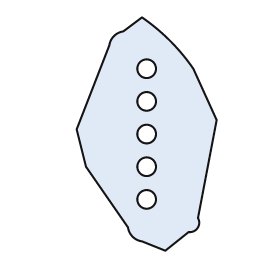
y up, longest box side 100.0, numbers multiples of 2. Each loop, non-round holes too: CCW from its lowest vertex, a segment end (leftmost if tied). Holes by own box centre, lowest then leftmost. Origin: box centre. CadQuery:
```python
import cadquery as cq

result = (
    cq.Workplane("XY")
    .moveTo(8.0, -50.0)
    .lineTo(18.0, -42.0)
    .threePointArc((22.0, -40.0), (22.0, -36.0))
    .lineTo(30.0, 6.0)
    .lineTo(20.0, 28.0)
    .threePointArc((10.0, 40.0), (-2.0, 50.0))
    .lineTo(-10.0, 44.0)
    .threePointArc((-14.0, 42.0), (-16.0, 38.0))
    .lineTo(-30.0, 2.0)
    .lineTo(-26.0, -14.0)
    .lineTo(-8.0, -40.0)
    .threePointArc((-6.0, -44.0), (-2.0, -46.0))
    .close()
    .moveTo(0.0, -28.0)
    .circle(4.0)
    .moveTo(0.0, -14.0)
    .circle(4.0)
    .moveTo(0.0, 0.0)
    .circle(4.0)
    .moveTo(0.0, 14.0)
    .circle(4.0)
    .moveTo(0.0, 28.0)
    .circle(4.0)
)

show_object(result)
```